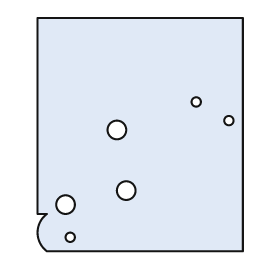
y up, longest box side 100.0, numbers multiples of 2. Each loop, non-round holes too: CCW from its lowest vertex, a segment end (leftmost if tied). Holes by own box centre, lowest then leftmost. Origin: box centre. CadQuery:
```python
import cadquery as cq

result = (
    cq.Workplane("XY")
    .moveTo(-40.0, -50.0)
    .lineTo(44.0, -50.0)
    .lineTo(44.0, 50.0)
    .lineTo(-44.0, 50.0)
    .lineTo(-44.0, -34.0)
    .lineTo(-40.0, -34.0)
    .threePointArc((-44.0, -42.0), (-40.0, -50.0))
    .close()
    .moveTo(-30.0, -44.0)
    .circle(2.0)
    .moveTo(-32.0, -30.0)
    .circle(4.0)
    .moveTo(-6.0, -24.0)
    .circle(4.0)
    .moveTo(-10.0, 2.0)
    .circle(4.0)
    .moveTo(38.0, 6.0)
    .circle(2.0)
    .moveTo(24.0, 14.0)
    .circle(2.0)
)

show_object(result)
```